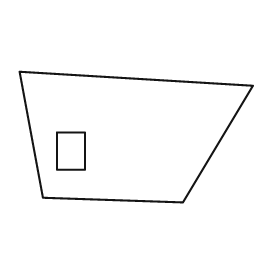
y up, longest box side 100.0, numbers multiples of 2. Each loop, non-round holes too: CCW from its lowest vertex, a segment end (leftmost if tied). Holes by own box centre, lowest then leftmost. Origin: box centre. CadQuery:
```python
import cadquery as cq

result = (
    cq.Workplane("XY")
    .moveTo(20.0, -28.0)
    .lineTo(50.0, 22.0)
    .lineTo(-50.0, 28.0)
    .lineTo(-40.0, -26.0)
    .close()
    .moveTo(-34.0, -14.0)
    .lineTo(-22.0, -14.0)
    .lineTo(-22.0, 2.0)
    .lineTo(-34.0, 2.0)
    .close()
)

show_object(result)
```